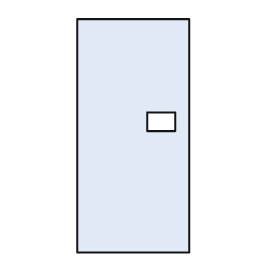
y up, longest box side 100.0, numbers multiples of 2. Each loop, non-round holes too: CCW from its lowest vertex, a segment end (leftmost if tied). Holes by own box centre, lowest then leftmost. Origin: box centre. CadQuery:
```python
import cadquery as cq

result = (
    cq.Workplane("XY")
    .moveTo(-24.0, -50.0)
    .lineTo(24.0, -50.0)
    .lineTo(24.0, 50.0)
    .lineTo(-24.0, 50.0)
    .close()
    .moveTo(6.0, 2.0)
    .lineTo(18.0, 2.0)
    .lineTo(18.0, 10.0)
    .lineTo(6.0, 10.0)
    .close()
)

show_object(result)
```